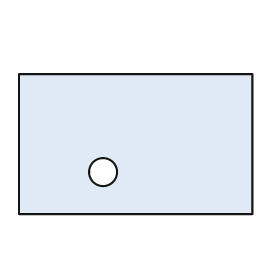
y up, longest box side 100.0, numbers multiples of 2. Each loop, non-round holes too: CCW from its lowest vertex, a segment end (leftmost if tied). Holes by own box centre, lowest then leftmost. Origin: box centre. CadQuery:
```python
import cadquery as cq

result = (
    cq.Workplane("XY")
    .moveTo(-50.0, -30.0)
    .lineTo(50.0, -30.0)
    .lineTo(50.0, 30.0)
    .lineTo(-50.0, 30.0)
    .close()
    .moveTo(-14.0, -12.0)
    .circle(6.0)
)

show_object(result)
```